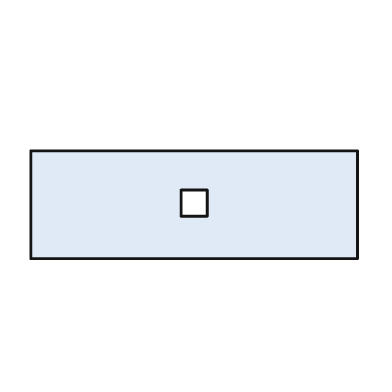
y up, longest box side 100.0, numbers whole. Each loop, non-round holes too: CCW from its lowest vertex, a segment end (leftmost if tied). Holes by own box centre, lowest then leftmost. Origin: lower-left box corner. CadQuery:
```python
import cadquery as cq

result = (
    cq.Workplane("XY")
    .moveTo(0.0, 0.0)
    .lineTo(100.0, 0.0)
    .lineTo(100.0, 33.0)
    .lineTo(0.0, 33.0)
    .close()
    .moveTo(46.0, 13.0)
    .lineTo(54.0, 13.0)
    .lineTo(54.0, 21.0)
    .lineTo(46.0, 21.0)
    .close()
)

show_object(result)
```